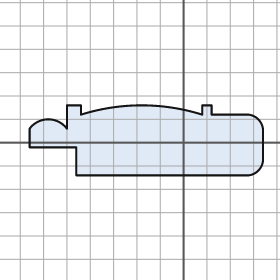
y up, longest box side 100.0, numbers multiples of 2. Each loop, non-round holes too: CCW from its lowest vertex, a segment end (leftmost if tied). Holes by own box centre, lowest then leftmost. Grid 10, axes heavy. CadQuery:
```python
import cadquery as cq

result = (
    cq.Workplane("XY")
    .moveTo(-46.0, -14.0)
    .lineTo(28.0, -14.0)
    .threePointArc((32.0, -12.0), (34.0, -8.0))
    .lineTo(34.0, 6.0)
    .threePointArc((32.0, 10.0), (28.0, 12.0))
    .lineTo(12.0, 12.0)
    .lineTo(12.0, 16.0)
    .lineTo(8.0, 16.0)
    .lineTo(8.0, 12.0)
    .threePointArc((-18.0, 16.0), (-44.0, 12.0))
    .lineTo(-44.0, 16.0)
    .lineTo(-50.0, 16.0)
    .lineTo(-50.0, 6.0)
    .threePointArc((-58.0, 10.0), (-66.0, 6.0))
    .lineTo(-66.0, -2.0)
    .lineTo(-46.0, -2.0)
    .close()
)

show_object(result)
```